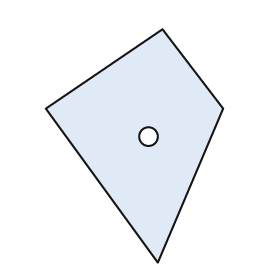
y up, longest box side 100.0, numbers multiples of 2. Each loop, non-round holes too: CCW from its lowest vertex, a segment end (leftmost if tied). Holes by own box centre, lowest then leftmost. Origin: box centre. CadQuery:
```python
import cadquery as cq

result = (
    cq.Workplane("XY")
    .moveTo(10.0, -50.0)
    .lineTo(38.0, 16.0)
    .lineTo(12.0, 50.0)
    .lineTo(-38.0, 16.0)
    .close()
    .moveTo(6.0, 4.0)
    .circle(4.0)
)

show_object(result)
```